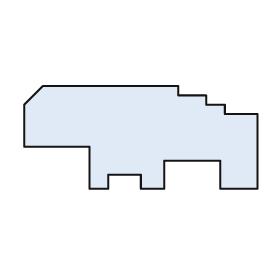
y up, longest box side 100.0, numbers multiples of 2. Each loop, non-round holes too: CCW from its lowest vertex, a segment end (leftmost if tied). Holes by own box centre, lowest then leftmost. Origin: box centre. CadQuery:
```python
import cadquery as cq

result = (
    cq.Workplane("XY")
    .moveTo(-22.0, -22.0)
    .lineTo(-14.0, -22.0)
    .lineTo(-14.0, -16.0)
    .lineTo(0.0, -16.0)
    .lineTo(0.0, -22.0)
    .lineTo(10.0, -22.0)
    .lineTo(10.0, -10.0)
    .lineTo(34.0, -10.0)
    .lineTo(34.0, -22.0)
    .lineTo(50.0, -22.0)
    .lineTo(50.0, 10.0)
    .lineTo(36.0, 10.0)
    .lineTo(36.0, 14.0)
    .lineTo(28.0, 14.0)
    .lineTo(28.0, 18.0)
    .lineTo(16.0, 18.0)
    .lineTo(16.0, 22.0)
    .lineTo(-42.0, 22.0)
    .lineTo(-50.0, 14.0)
    .lineTo(-50.0, -4.0)
    .lineTo(-22.0, -4.0)
    .close()
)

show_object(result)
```